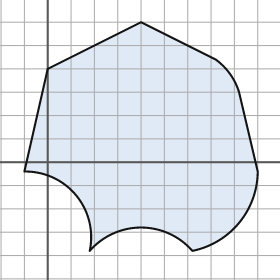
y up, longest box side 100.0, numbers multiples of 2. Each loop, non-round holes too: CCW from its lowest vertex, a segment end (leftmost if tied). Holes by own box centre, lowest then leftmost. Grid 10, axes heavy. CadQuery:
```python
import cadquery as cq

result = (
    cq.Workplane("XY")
    .moveTo(18.0, -38.0)
    .threePointArc((40.0, -28.0), (62.0, -38.0))
    .threePointArc((82.0, -26.0), (90.0, -4.0))
    .lineTo(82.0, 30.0)
    .threePointArc((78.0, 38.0), (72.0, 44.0))
    .lineTo(40.0, 60.0)
    .lineTo(0.0, 40.0)
    .lineTo(-10.0, -4.0)
    .threePointArc((12.0, -14.0), (18.0, -38.0))
    .close()
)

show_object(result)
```